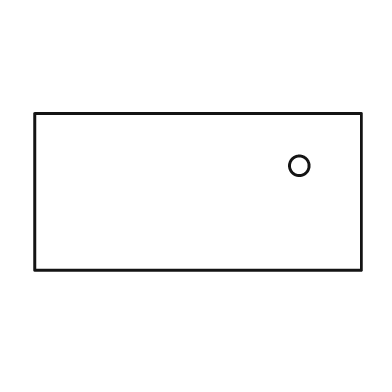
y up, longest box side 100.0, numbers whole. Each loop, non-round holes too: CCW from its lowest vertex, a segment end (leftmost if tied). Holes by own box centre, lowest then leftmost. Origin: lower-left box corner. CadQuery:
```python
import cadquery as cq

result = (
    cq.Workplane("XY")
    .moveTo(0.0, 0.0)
    .lineTo(100.0, 0.0)
    .lineTo(100.0, 48.0)
    .lineTo(0.0, 48.0)
    .close()
    .moveTo(81.0, 32.0)
    .circle(3.0)
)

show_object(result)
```